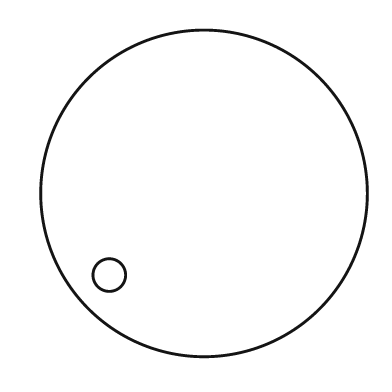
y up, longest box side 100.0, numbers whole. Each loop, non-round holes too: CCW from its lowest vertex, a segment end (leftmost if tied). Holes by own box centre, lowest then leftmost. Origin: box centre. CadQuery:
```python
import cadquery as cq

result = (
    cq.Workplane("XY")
    .moveTo(0.0, 0.0)
    .circle(50.0)
    .moveTo(-29.0, -25.0)
    .circle(5.0)
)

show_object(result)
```